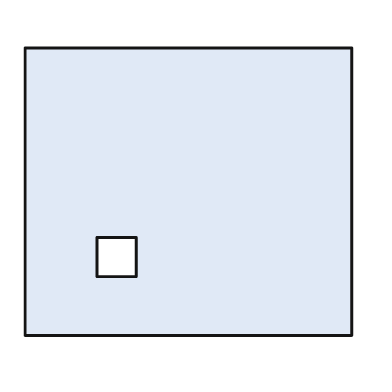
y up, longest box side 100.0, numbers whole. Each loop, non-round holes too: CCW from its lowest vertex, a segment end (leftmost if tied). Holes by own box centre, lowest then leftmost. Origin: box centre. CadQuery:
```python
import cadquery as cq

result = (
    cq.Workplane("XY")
    .moveTo(-50.0, -44.0)
    .lineTo(50.0, -44.0)
    .lineTo(50.0, 44.0)
    .lineTo(-50.0, 44.0)
    .close()
    .moveTo(-28.0, -26.0)
    .lineTo(-16.0, -26.0)
    .lineTo(-16.0, -14.0)
    .lineTo(-28.0, -14.0)
    .close()
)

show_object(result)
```